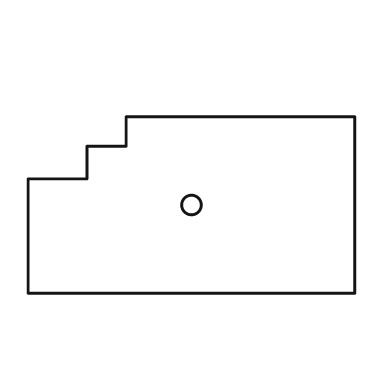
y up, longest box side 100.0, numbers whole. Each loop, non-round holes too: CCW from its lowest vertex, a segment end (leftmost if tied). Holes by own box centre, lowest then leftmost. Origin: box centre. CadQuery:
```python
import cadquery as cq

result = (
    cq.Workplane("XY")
    .moveTo(-50.0, -27.0)
    .lineTo(50.0, -27.0)
    .lineTo(50.0, 27.0)
    .lineTo(-20.0, 27.0)
    .lineTo(-20.0, 18.0)
    .lineTo(-32.0, 18.0)
    .lineTo(-32.0, 8.0)
    .lineTo(-50.0, 8.0)
    .close()
    .moveTo(0.0, 0.0)
    .circle(3.0)
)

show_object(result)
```